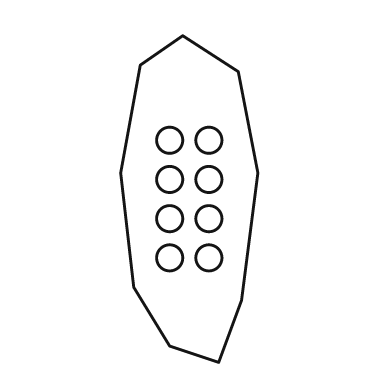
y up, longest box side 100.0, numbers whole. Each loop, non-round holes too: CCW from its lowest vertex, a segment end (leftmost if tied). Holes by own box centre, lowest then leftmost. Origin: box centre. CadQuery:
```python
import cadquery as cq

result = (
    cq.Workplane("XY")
    .moveTo(9.0, -50.0)
    .lineTo(16.0, -31.0)
    .lineTo(21.0, 8.0)
    .lineTo(15.0, 39.0)
    .lineTo(-2.0, 50.0)
    .lineTo(-15.0, 41.0)
    .lineTo(-21.0, 8.0)
    .lineTo(-17.0, -27.0)
    .lineTo(-6.0, -45.0)
    .close()
    .moveTo(-6.0, -18.0)
    .circle(4.0)
    .moveTo(6.0, -18.0)
    .circle(4.0)
    .moveTo(-6.0, -6.0)
    .circle(4.0)
    .moveTo(6.0, -6.0)
    .circle(4.0)
    .moveTo(-6.0, 6.0)
    .circle(4.0)
    .moveTo(6.0, 6.0)
    .circle(4.0)
    .moveTo(-6.0, 18.0)
    .circle(4.0)
    .moveTo(6.0, 18.0)
    .circle(4.0)
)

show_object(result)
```